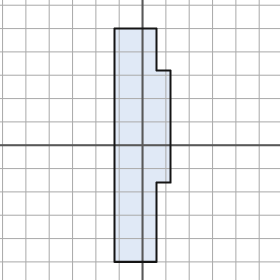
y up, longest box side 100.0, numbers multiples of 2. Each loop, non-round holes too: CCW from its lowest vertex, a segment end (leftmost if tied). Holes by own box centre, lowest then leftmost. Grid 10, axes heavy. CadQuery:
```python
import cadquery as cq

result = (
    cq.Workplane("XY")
    .moveTo(-12.0, -50.0)
    .lineTo(6.0, -50.0)
    .lineTo(6.0, -16.0)
    .lineTo(12.0, -16.0)
    .lineTo(12.0, 32.0)
    .lineTo(6.0, 32.0)
    .lineTo(6.0, 50.0)
    .lineTo(-12.0, 50.0)
    .close()
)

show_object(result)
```